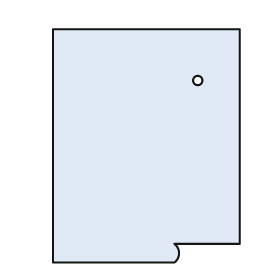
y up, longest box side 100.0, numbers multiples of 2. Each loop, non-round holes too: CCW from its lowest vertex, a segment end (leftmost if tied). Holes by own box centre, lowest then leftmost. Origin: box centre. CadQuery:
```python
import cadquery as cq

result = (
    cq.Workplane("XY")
    .moveTo(-40.0, -50.0)
    .lineTo(12.0, -50.0)
    .threePointArc((14.0, -46.0), (12.0, -42.0))
    .lineTo(40.0, -42.0)
    .lineTo(40.0, 50.0)
    .lineTo(-40.0, 50.0)
    .close()
    .moveTo(22.0, 28.0)
    .circle(2.0)
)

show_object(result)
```